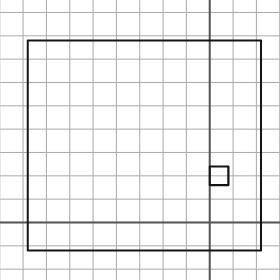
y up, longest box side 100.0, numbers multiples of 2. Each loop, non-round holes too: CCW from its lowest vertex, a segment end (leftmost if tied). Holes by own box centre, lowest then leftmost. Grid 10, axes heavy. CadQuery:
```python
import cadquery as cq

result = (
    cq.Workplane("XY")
    .moveTo(-78.0, -12.0)
    .lineTo(22.0, -12.0)
    .lineTo(22.0, 78.0)
    .lineTo(-78.0, 78.0)
    .close()
    .moveTo(0.0, 16.0)
    .lineTo(8.0, 16.0)
    .lineTo(8.0, 24.0)
    .lineTo(0.0, 24.0)
    .close()
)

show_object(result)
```